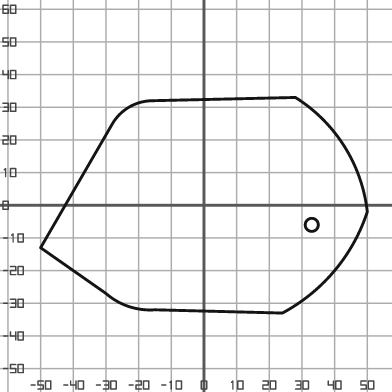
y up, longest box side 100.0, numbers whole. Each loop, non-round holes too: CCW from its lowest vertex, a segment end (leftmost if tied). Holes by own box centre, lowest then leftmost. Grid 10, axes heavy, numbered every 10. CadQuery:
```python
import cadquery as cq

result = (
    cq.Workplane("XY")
    .moveTo(24.0, -33.0)
    .threePointArc((40.0, -20.0), (50.0, -2.0))
    .threePointArc((43.0, 18.0), (28.0, 33.0))
    .lineTo(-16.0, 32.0)
    .threePointArc((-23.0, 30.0), (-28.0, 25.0))
    .lineTo(-50.0, -13.0)
    .lineTo(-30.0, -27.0)
    .threePointArc((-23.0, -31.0), (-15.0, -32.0))
    .close()
    .moveTo(33.0, -6.0)
    .circle(2.0)
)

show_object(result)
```